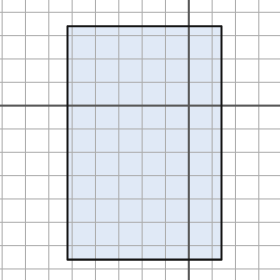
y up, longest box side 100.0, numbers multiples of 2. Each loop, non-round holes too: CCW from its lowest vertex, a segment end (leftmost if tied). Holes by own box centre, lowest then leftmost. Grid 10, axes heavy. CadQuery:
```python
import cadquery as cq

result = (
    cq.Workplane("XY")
    .moveTo(-52.0, -66.0)
    .lineTo(14.0, -66.0)
    .lineTo(14.0, 34.0)
    .lineTo(-52.0, 34.0)
    .close()
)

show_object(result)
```